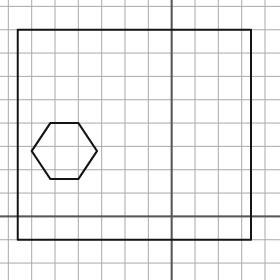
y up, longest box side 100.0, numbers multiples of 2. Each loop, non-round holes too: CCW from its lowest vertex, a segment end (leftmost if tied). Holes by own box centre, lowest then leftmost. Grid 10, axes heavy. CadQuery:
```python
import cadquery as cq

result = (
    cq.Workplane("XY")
    .moveTo(-66.0, -10.0)
    .lineTo(34.0, -10.0)
    .lineTo(34.0, 80.0)
    .lineTo(-66.0, 80.0)
    .close()
    .moveTo(-52.0, 16.0)
    .lineTo(-40.0, 16.0)
    .lineTo(-32.0, 28.0)
    .lineTo(-40.0, 40.0)
    .lineTo(-52.0, 40.0)
    .lineTo(-60.0, 28.0)
    .close()
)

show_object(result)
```